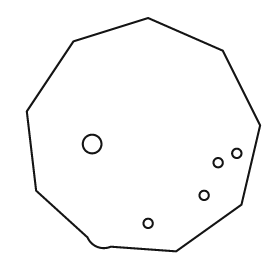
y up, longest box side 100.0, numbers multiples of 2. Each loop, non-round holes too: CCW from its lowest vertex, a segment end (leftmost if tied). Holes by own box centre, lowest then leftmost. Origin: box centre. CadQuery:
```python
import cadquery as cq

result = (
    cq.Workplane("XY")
    .moveTo(14.0, -50.0)
    .lineTo(42.0, -30.0)
    .lineTo(50.0, 4.0)
    .lineTo(34.0, 36.0)
    .lineTo(2.0, 50.0)
    .lineTo(-30.0, 40.0)
    .lineTo(-50.0, 10.0)
    .lineTo(-46.0, -24.0)
    .lineTo(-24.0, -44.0)
    .threePointArc((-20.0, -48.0), (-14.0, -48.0))
    .close()
    .moveTo(2.0, -38.0)
    .circle(2.0)
    .moveTo(26.0, -26.0)
    .circle(2.0)
    .moveTo(32.0, -12.0)
    .circle(2.0)
    .moveTo(40.0, -8.0)
    .circle(2.0)
    .moveTo(-22.0, -4.0)
    .circle(4.0)
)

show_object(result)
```